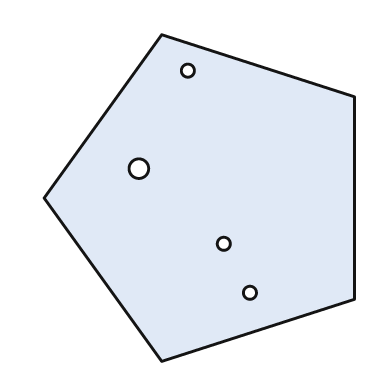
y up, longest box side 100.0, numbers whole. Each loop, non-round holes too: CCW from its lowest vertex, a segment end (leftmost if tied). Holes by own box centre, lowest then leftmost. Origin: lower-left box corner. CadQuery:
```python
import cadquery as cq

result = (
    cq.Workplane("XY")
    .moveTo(36.0, 0.0)
    .lineTo(95.0, 19.0)
    .lineTo(95.0, 81.0)
    .lineTo(36.0, 100.0)
    .lineTo(0.0, 50.0)
    .close()
    .moveTo(63.0, 21.0)
    .circle(2.0)
    .moveTo(55.0, 36.0)
    .circle(2.0)
    .moveTo(29.0, 59.0)
    .circle(3.0)
    .moveTo(44.0, 89.0)
    .circle(2.0)
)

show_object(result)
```